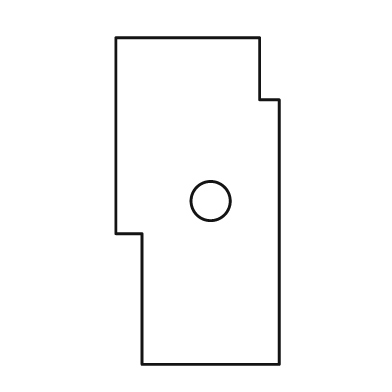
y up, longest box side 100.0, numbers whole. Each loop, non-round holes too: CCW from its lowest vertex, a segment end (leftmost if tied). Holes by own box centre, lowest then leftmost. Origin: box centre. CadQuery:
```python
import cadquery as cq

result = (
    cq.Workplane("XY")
    .moveTo(-17.0, -50.0)
    .lineTo(25.0, -50.0)
    .lineTo(25.0, 31.0)
    .lineTo(19.0, 31.0)
    .lineTo(19.0, 50.0)
    .lineTo(-25.0, 50.0)
    .lineTo(-25.0, -10.0)
    .lineTo(-17.0, -10.0)
    .close()
    .moveTo(4.0, 0.0)
    .circle(6.0)
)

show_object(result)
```